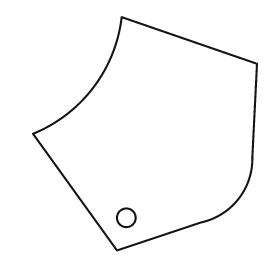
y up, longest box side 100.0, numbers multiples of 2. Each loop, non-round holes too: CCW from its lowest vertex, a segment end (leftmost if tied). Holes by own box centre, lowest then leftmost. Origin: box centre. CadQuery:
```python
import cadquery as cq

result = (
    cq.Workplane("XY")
    .moveTo(-12.0, -50.0)
    .lineTo(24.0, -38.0)
    .threePointArc((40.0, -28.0), (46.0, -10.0))
    .lineTo(48.0, 30.0)
    .lineTo(-10.0, 50.0)
    .threePointArc((-22.0, 20.0), (-48.0, 0.0))
    .close()
    .moveTo(-8.0, -36.0)
    .circle(4.0)
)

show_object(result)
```